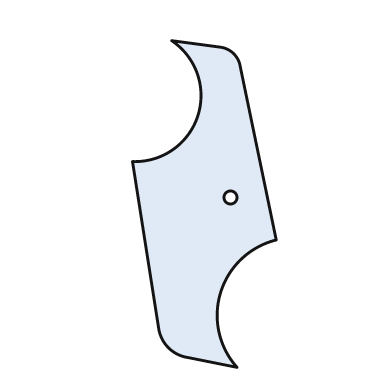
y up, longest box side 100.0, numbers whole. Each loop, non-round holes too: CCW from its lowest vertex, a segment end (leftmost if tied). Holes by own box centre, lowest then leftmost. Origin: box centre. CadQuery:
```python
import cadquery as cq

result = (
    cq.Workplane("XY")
    .moveTo(10.0, -50.0)
    .threePointArc((5.0, -27.0), (22.0, -11.0))
    .lineTo(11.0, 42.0)
    .threePointArc((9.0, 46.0), (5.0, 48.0))
    .lineTo(-10.0, 50.0)
    .threePointArc((-2.0, 27.0), (-22.0, 13.0))
    .lineTo(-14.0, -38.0)
    .threePointArc((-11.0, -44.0), (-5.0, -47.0))
    .close()
    .moveTo(8.0, 2.0)
    .circle(2.0)
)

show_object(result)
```